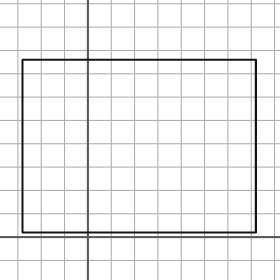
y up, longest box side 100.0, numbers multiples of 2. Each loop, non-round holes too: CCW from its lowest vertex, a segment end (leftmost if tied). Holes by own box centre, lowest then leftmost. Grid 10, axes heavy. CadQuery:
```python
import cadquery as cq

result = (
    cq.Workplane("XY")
    .moveTo(-28.0, 2.0)
    .lineTo(72.0, 2.0)
    .lineTo(72.0, 76.0)
    .lineTo(-28.0, 76.0)
    .close()
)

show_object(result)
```